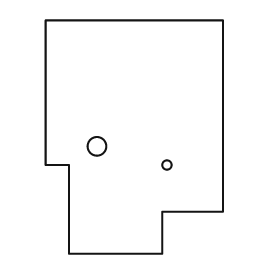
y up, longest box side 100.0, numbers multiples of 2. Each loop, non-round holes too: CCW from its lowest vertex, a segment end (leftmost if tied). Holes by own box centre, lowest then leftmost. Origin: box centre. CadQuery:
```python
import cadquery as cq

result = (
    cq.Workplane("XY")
    .moveTo(-28.0, -50.0)
    .lineTo(12.0, -50.0)
    .lineTo(12.0, -32.0)
    .lineTo(38.0, -32.0)
    .lineTo(38.0, 50.0)
    .lineTo(-38.0, 50.0)
    .lineTo(-38.0, -12.0)
    .lineTo(-28.0, -12.0)
    .close()
    .moveTo(14.0, -12.0)
    .circle(2.0)
    .moveTo(-16.0, -4.0)
    .circle(4.0)
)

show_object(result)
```